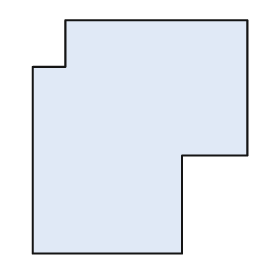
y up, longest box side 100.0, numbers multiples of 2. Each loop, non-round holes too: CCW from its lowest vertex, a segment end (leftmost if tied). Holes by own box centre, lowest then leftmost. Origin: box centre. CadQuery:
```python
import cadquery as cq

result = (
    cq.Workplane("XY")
    .moveTo(-46.0, -50.0)
    .lineTo(18.0, -50.0)
    .lineTo(18.0, -8.0)
    .lineTo(46.0, -8.0)
    .lineTo(46.0, 50.0)
    .lineTo(-32.0, 50.0)
    .lineTo(-32.0, 30.0)
    .lineTo(-46.0, 30.0)
    .close()
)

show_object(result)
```